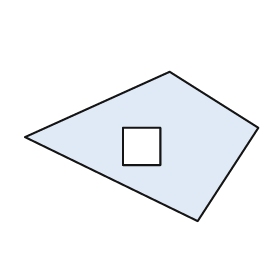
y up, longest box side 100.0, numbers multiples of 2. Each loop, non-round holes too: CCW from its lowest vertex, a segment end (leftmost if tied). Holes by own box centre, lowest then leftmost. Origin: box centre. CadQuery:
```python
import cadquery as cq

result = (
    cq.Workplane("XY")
    .moveTo(24.0, -32.0)
    .lineTo(50.0, 8.0)
    .lineTo(12.0, 32.0)
    .lineTo(-50.0, 4.0)
    .close()
    .moveTo(-8.0, -8.0)
    .lineTo(8.0, -8.0)
    .lineTo(8.0, 8.0)
    .lineTo(-8.0, 8.0)
    .close()
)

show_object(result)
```